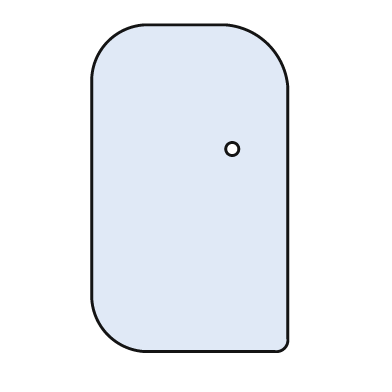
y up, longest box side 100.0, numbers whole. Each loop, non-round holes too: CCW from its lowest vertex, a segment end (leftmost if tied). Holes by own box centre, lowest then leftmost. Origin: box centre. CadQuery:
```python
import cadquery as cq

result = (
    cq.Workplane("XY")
    .moveTo(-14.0, -50.0)
    .lineTo(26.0, -50.0)
    .threePointArc((29.0, -49.0), (30.0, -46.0))
    .lineTo(30.0, 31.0)
    .threePointArc((24.0, 44.0), (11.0, 50.0))
    .lineTo(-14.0, 50.0)
    .threePointArc((-25.0, 45.0), (-30.0, 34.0))
    .lineTo(-30.0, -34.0)
    .threePointArc((-25.0, -45.0), (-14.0, -50.0))
    .close()
    .moveTo(13.0, 12.0)
    .circle(2.0)
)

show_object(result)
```